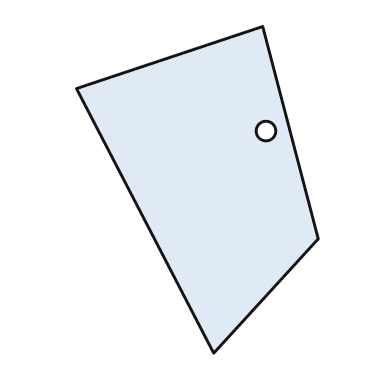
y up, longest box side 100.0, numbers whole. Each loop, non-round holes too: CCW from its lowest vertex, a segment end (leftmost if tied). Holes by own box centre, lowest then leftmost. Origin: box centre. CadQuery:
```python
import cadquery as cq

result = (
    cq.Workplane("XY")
    .moveTo(5.0, -50.0)
    .lineTo(37.0, -15.0)
    .lineTo(20.0, 50.0)
    .lineTo(-37.0, 31.0)
    .close()
    .moveTo(21.0, 18.0)
    .circle(3.0)
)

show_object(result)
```